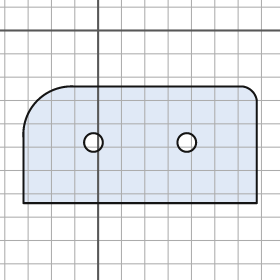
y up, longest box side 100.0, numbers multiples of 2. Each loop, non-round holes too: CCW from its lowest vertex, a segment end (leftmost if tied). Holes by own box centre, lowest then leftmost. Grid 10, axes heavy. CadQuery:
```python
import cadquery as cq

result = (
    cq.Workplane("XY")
    .moveTo(-32.0, -74.0)
    .lineTo(68.0, -74.0)
    .lineTo(68.0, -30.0)
    .threePointArc((66.0, -26.0), (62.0, -24.0))
    .lineTo(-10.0, -24.0)
    .threePointArc((-26.0, -30.0), (-32.0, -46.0))
    .close()
    .moveTo(-2.0, -48.0)
    .circle(4.0)
    .moveTo(38.0, -48.0)
    .circle(4.0)
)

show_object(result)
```